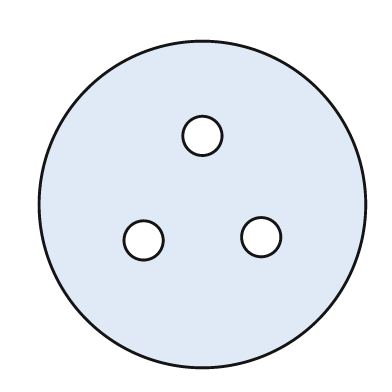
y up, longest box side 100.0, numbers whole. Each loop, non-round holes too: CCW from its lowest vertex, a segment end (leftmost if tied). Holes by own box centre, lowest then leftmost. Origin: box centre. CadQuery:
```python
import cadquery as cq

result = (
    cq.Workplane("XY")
    .moveTo(0.0, 0.0)
    .circle(50.0)
    .moveTo(-18.0, -11.0)
    .circle(6.0)
    .moveTo(18.0, -10.0)
    .circle(6.0)
    .moveTo(0.0, 21.0)
    .circle(6.0)
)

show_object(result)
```